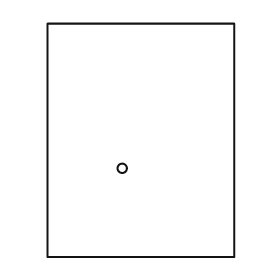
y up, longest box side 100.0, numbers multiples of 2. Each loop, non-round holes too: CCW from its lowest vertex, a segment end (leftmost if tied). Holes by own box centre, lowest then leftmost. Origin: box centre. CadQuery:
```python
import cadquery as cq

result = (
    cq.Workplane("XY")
    .moveTo(-40.0, -50.0)
    .lineTo(40.0, -50.0)
    .lineTo(40.0, 50.0)
    .lineTo(-40.0, 50.0)
    .close()
    .moveTo(-8.0, -12.0)
    .circle(2.0)
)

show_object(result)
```